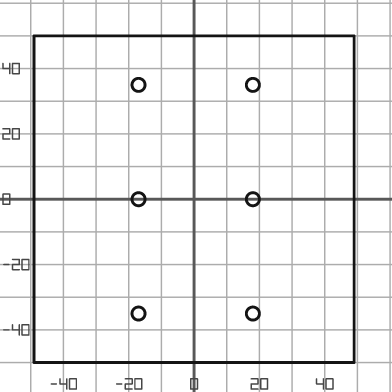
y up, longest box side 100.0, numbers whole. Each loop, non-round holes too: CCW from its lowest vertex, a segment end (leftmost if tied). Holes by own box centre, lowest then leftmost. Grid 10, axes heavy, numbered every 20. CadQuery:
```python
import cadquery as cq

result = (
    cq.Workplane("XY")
    .moveTo(-49.0, -50.0)
    .lineTo(49.0, -50.0)
    .lineTo(49.0, 50.0)
    .lineTo(-49.0, 50.0)
    .close()
    .moveTo(-17.0, -35.0)
    .circle(2.0)
    .moveTo(18.0, -35.0)
    .circle(2.0)
    .moveTo(-17.0, 0.0)
    .circle(2.0)
    .moveTo(18.0, 0.0)
    .circle(2.0)
    .moveTo(-17.0, 35.0)
    .circle(2.0)
    .moveTo(18.0, 35.0)
    .circle(2.0)
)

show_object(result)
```